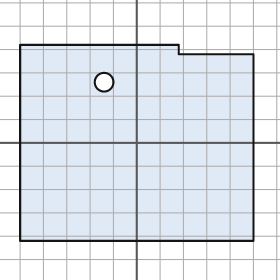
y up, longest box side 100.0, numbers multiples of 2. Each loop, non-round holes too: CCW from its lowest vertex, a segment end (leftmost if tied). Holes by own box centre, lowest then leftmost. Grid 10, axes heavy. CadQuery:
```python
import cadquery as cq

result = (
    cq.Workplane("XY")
    .moveTo(-50.0, -42.0)
    .lineTo(50.0, -42.0)
    .lineTo(50.0, 38.0)
    .lineTo(18.0, 38.0)
    .lineTo(18.0, 42.0)
    .lineTo(-50.0, 42.0)
    .close()
    .moveTo(-14.0, 26.0)
    .circle(4.0)
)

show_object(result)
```